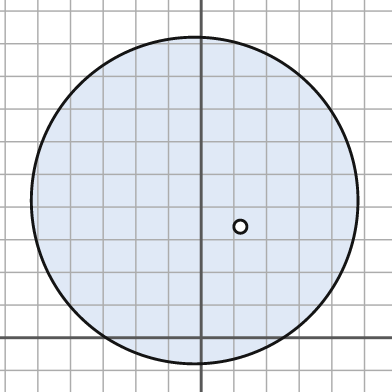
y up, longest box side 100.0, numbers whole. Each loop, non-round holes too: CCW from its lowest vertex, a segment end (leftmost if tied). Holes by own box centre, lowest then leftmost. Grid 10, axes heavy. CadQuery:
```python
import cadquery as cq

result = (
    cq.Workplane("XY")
    .moveTo(-2.0, 42.0)
    .circle(50.0)
    .moveTo(12.0, 34.0)
    .circle(2.0)
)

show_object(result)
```